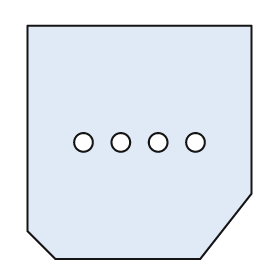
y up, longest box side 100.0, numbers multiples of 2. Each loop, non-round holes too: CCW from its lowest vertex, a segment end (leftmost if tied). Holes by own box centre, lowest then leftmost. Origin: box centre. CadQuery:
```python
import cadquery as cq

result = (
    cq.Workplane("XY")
    .moveTo(-36.0, -50.0)
    .lineTo(26.0, -50.0)
    .lineTo(48.0, -22.0)
    .lineTo(48.0, 50.0)
    .lineTo(-48.0, 50.0)
    .lineTo(-48.0, -38.0)
    .close()
    .moveTo(-24.0, 0.0)
    .circle(4.0)
    .moveTo(-8.0, 0.0)
    .circle(4.0)
    .moveTo(8.0, 0.0)
    .circle(4.0)
    .moveTo(24.0, 0.0)
    .circle(4.0)
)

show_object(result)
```